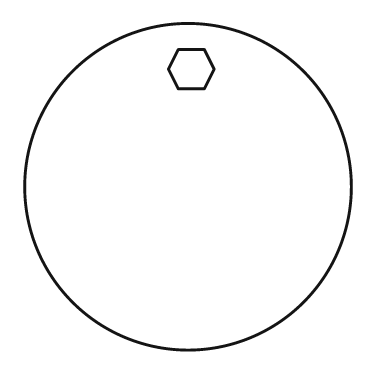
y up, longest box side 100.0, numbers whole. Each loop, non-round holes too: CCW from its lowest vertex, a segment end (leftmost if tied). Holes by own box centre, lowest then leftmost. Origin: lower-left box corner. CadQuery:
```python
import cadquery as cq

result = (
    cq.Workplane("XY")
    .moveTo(50.0, 50.0)
    .circle(50.0)
    .moveTo(47.0, 80.0)
    .lineTo(55.0, 80.0)
    .lineTo(58.0, 86.0)
    .lineTo(55.0, 92.0)
    .lineTo(47.0, 92.0)
    .lineTo(44.0, 86.0)
    .close()
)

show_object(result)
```